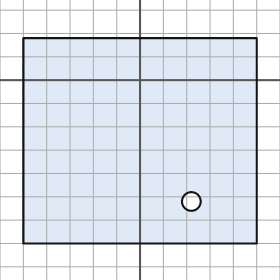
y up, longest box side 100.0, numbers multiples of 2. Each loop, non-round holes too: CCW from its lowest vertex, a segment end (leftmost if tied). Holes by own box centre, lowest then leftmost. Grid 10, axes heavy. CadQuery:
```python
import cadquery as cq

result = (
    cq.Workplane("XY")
    .moveTo(-50.0, -70.0)
    .lineTo(50.0, -70.0)
    .lineTo(50.0, 18.0)
    .lineTo(-50.0, 18.0)
    .close()
    .moveTo(22.0, -52.0)
    .circle(4.0)
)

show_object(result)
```